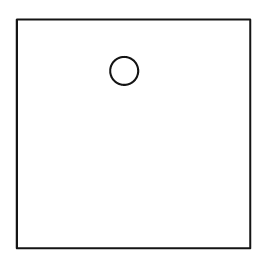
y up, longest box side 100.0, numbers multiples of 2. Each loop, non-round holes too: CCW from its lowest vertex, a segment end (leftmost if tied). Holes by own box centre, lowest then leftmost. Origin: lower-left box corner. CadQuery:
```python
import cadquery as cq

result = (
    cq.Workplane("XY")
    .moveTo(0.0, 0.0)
    .lineTo(100.0, 0.0)
    .lineTo(100.0, 98.0)
    .lineTo(0.0, 98.0)
    .close()
    .moveTo(46.0, 76.0)
    .circle(6.0)
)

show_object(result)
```